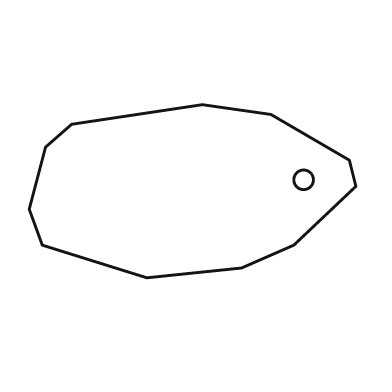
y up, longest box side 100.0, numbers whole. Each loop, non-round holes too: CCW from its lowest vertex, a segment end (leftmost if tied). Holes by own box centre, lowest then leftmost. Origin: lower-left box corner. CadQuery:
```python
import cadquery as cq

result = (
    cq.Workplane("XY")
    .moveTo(36.0, 0.0)
    .lineTo(65.0, 3.0)
    .lineTo(81.0, 10.0)
    .lineTo(100.0, 28.0)
    .lineTo(98.0, 36.0)
    .lineTo(74.0, 50.0)
    .lineTo(53.0, 53.0)
    .lineTo(13.0, 47.0)
    .lineTo(5.0, 40.0)
    .lineTo(0.0, 21.0)
    .lineTo(4.0, 10.0)
    .close()
    .moveTo(84.0, 30.0)
    .circle(3.0)
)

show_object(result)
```